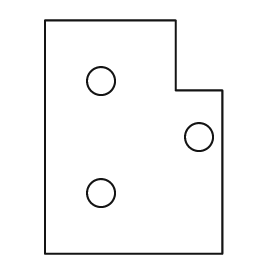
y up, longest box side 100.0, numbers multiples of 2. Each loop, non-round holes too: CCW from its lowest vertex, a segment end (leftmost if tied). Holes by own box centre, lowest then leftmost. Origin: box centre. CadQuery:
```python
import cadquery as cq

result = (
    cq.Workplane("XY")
    .moveTo(-38.0, -50.0)
    .lineTo(38.0, -50.0)
    .lineTo(38.0, 20.0)
    .lineTo(18.0, 20.0)
    .lineTo(18.0, 50.0)
    .lineTo(-38.0, 50.0)
    .close()
    .moveTo(-14.0, -24.0)
    .circle(6.0)
    .moveTo(28.0, 0.0)
    .circle(6.0)
    .moveTo(-14.0, 24.0)
    .circle(6.0)
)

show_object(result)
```